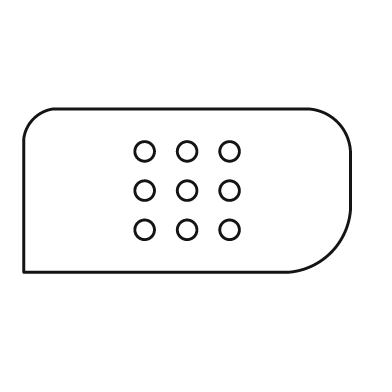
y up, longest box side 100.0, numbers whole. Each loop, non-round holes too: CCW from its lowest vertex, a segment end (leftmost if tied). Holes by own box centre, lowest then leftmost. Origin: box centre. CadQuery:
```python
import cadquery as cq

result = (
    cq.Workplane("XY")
    .moveTo(-50.0, -25.0)
    .lineTo(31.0, -25.0)
    .threePointArc((44.0, -19.0), (50.0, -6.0))
    .lineTo(50.0, 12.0)
    .threePointArc((46.0, 21.0), (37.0, 25.0))
    .lineTo(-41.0, 25.0)
    .threePointArc((-47.0, 22.0), (-50.0, 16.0))
    .close()
    .moveTo(-13.0, -12.0)
    .circle(3.0)
    .moveTo(0.0, -12.0)
    .circle(3.0)
    .moveTo(13.0, -12.0)
    .circle(3.0)
    .moveTo(-13.0, 0.0)
    .circle(3.0)
    .moveTo(0.0, 0.0)
    .circle(3.0)
    .moveTo(13.0, 0.0)
    .circle(3.0)
    .moveTo(-13.0, 12.0)
    .circle(3.0)
    .moveTo(0.0, 12.0)
    .circle(3.0)
    .moveTo(13.0, 12.0)
    .circle(3.0)
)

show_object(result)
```